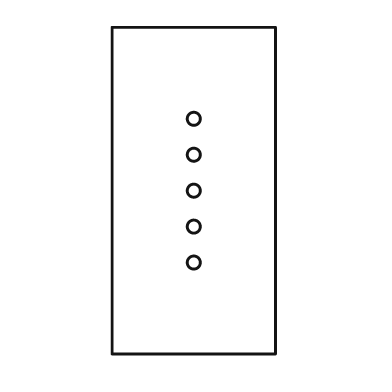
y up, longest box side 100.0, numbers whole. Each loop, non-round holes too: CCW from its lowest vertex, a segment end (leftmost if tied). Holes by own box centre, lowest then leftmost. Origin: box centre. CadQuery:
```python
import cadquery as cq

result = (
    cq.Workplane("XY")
    .moveTo(-25.0, -50.0)
    .lineTo(25.0, -50.0)
    .lineTo(25.0, 50.0)
    .lineTo(-25.0, 50.0)
    .close()
    .moveTo(0.0, -22.0)
    .circle(2.0)
    .moveTo(0.0, -11.0)
    .circle(2.0)
    .moveTo(0.0, 0.0)
    .circle(2.0)
    .moveTo(0.0, 11.0)
    .circle(2.0)
    .moveTo(0.0, 22.0)
    .circle(2.0)
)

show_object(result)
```